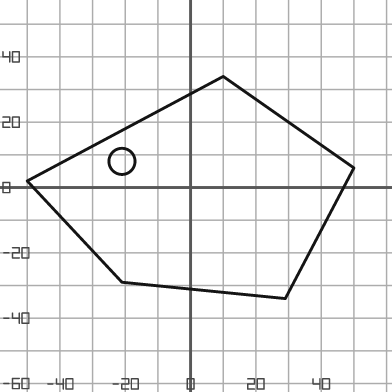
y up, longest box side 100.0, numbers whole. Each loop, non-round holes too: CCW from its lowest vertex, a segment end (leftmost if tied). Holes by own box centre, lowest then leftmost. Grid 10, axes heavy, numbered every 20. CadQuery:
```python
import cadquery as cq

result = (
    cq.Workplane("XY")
    .moveTo(29.0, -34.0)
    .lineTo(50.0, 6.0)
    .lineTo(10.0, 34.0)
    .lineTo(-50.0, 2.0)
    .lineTo(-21.0, -29.0)
    .close()
    .moveTo(-21.0, 8.0)
    .circle(4.0)
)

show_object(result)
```